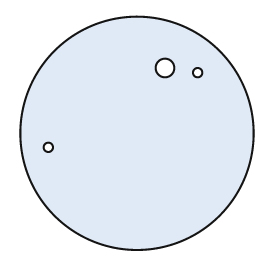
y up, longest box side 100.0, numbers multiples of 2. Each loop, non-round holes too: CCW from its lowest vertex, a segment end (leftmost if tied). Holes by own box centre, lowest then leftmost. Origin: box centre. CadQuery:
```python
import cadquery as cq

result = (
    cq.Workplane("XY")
    .moveTo(0.0, 0.0)
    .circle(50.0)
    .moveTo(-38.0, -6.0)
    .circle(2.0)
    .moveTo(26.0, 26.0)
    .circle(2.0)
    .moveTo(12.0, 28.0)
    .circle(4.0)
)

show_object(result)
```